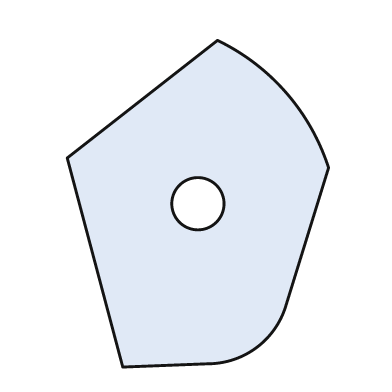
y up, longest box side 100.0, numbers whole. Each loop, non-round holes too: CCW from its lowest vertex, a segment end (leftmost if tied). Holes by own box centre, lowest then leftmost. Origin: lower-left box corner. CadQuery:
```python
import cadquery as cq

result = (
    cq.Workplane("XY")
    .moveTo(17.0, 0.0)
    .lineTo(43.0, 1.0)
    .threePointArc((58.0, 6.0), (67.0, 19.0))
    .lineTo(80.0, 61.0)
    .threePointArc((67.0, 84.0), (46.0, 100.0))
    .lineTo(0.0, 64.0)
    .close()
    .moveTo(40.0, 50.0)
    .circle(8.0)
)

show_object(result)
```